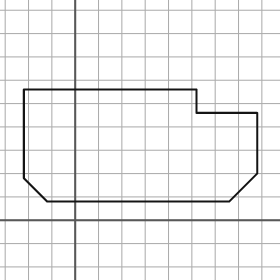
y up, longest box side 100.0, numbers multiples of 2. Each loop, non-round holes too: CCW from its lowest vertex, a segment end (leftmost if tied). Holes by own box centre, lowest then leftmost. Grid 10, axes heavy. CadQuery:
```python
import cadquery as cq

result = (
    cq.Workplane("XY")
    .moveTo(-12.0, 8.0)
    .lineTo(66.0, 8.0)
    .lineTo(78.0, 20.0)
    .lineTo(78.0, 46.0)
    .lineTo(52.0, 46.0)
    .lineTo(52.0, 56.0)
    .lineTo(-22.0, 56.0)
    .lineTo(-22.0, 18.0)
    .close()
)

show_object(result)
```